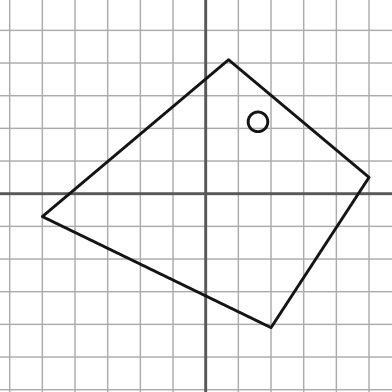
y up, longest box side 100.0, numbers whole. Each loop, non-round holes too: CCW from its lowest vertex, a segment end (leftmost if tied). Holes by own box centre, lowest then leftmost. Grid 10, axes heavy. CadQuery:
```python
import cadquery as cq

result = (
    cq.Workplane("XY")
    .moveTo(20.0, -41.0)
    .lineTo(50.0, 5.0)
    .lineTo(7.0, 41.0)
    .lineTo(-50.0, -7.0)
    .close()
    .moveTo(16.0, 22.0)
    .circle(3.0)
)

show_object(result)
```